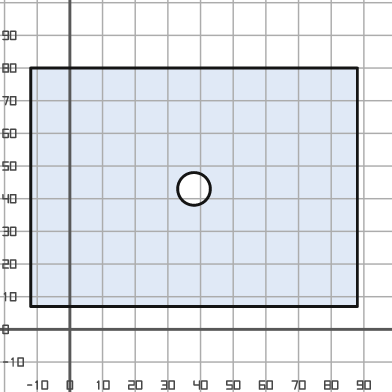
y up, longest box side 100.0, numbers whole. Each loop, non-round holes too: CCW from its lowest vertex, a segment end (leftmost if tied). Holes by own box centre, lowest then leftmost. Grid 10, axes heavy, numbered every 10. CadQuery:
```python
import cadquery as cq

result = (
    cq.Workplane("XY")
    .moveTo(-12.0, 7.0)
    .lineTo(88.0, 7.0)
    .lineTo(88.0, 80.0)
    .lineTo(-12.0, 80.0)
    .close()
    .moveTo(38.0, 43.0)
    .circle(5.0)
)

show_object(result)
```